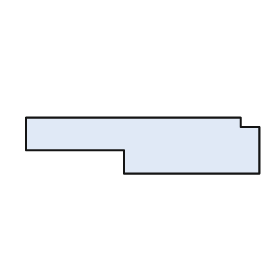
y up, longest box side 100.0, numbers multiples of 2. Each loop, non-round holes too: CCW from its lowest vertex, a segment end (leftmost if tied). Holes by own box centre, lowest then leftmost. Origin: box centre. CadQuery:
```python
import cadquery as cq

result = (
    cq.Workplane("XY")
    .moveTo(-8.0, -12.0)
    .lineTo(50.0, -12.0)
    .lineTo(50.0, 8.0)
    .lineTo(42.0, 8.0)
    .lineTo(42.0, 12.0)
    .lineTo(-50.0, 12.0)
    .lineTo(-50.0, -2.0)
    .lineTo(-8.0, -2.0)
    .close()
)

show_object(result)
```